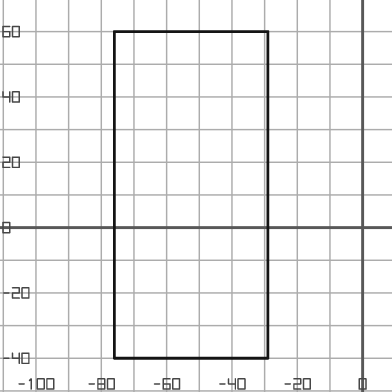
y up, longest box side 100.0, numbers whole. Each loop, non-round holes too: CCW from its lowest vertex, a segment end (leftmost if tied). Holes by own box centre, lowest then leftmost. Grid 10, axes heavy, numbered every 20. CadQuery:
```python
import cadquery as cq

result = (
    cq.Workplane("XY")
    .moveTo(-76.0, -40.0)
    .lineTo(-29.0, -40.0)
    .lineTo(-29.0, 60.0)
    .lineTo(-76.0, 60.0)
    .close()
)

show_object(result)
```